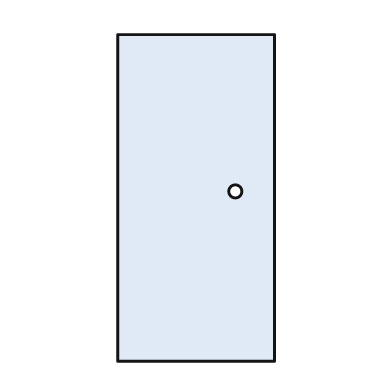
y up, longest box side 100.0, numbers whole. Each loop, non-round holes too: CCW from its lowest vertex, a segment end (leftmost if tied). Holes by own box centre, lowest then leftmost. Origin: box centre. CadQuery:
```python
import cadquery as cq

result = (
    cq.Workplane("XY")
    .moveTo(-24.0, -50.0)
    .lineTo(24.0, -50.0)
    .lineTo(24.0, 50.0)
    .lineTo(-24.0, 50.0)
    .close()
    .moveTo(12.0, 2.0)
    .circle(2.0)
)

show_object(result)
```